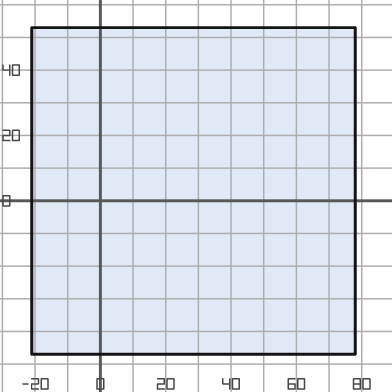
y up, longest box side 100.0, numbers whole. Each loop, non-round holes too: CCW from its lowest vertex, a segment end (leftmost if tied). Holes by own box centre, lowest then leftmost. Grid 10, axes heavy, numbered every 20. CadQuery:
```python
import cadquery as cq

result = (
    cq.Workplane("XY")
    .moveTo(-21.0, -47.0)
    .lineTo(78.0, -47.0)
    .lineTo(78.0, 53.0)
    .lineTo(-21.0, 53.0)
    .close()
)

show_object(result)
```